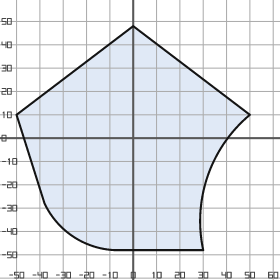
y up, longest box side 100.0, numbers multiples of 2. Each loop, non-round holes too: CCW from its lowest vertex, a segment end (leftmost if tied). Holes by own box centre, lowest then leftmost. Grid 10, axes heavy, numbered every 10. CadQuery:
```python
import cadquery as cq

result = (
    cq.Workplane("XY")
    .moveTo(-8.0, -48.0)
    .lineTo(30.0, -48.0)
    .threePointArc((32.0, -16.0), (50.0, 10.0))
    .lineTo(0.0, 48.0)
    .lineTo(-50.0, 10.0)
    .lineTo(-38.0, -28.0)
    .threePointArc((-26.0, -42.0), (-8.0, -48.0))
    .close()
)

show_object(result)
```